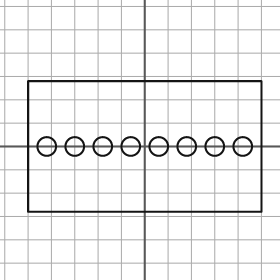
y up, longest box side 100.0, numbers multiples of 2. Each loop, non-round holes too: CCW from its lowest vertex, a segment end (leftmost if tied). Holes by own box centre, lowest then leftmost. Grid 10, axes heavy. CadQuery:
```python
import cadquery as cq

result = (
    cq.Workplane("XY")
    .moveTo(-50.0, -28.0)
    .lineTo(50.0, -28.0)
    .lineTo(50.0, 28.0)
    .lineTo(-50.0, 28.0)
    .close()
    .moveTo(-42.0, 0.0)
    .circle(4.0)
    .moveTo(-30.0, 0.0)
    .circle(4.0)
    .moveTo(-18.0, 0.0)
    .circle(4.0)
    .moveTo(-6.0, 0.0)
    .circle(4.0)
    .moveTo(6.0, 0.0)
    .circle(4.0)
    .moveTo(18.0, 0.0)
    .circle(4.0)
    .moveTo(30.0, 0.0)
    .circle(4.0)
    .moveTo(42.0, 0.0)
    .circle(4.0)
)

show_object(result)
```